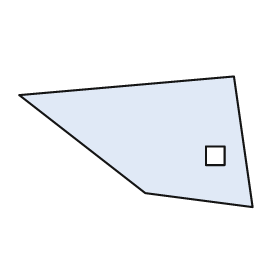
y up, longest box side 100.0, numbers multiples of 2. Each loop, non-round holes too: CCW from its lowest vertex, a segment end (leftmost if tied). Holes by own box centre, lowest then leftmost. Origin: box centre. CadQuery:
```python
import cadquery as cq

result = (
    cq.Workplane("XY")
    .moveTo(50.0, -28.0)
    .lineTo(42.0, 28.0)
    .lineTo(-50.0, 20.0)
    .lineTo(4.0, -22.0)
    .close()
    .moveTo(30.0, -10.0)
    .lineTo(38.0, -10.0)
    .lineTo(38.0, -2.0)
    .lineTo(30.0, -2.0)
    .close()
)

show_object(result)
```